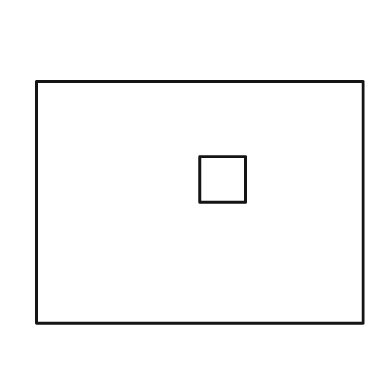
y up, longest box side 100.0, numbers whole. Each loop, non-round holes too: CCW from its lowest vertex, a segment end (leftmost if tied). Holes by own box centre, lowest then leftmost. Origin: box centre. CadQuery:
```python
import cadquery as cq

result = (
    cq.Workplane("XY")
    .moveTo(-50.0, -37.0)
    .lineTo(50.0, -37.0)
    .lineTo(50.0, 37.0)
    .lineTo(-50.0, 37.0)
    .close()
    .moveTo(0.0, 0.0)
    .lineTo(14.0, 0.0)
    .lineTo(14.0, 14.0)
    .lineTo(0.0, 14.0)
    .close()
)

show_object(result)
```